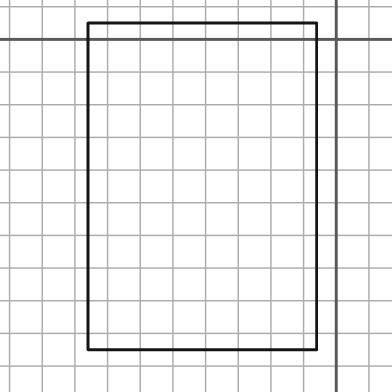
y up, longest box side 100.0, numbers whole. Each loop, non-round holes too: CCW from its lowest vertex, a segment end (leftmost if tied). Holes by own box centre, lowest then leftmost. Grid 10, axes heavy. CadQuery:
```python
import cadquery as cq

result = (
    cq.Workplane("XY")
    .moveTo(-76.0, -95.0)
    .lineTo(-6.0, -95.0)
    .lineTo(-6.0, 5.0)
    .lineTo(-76.0, 5.0)
    .close()
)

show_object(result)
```